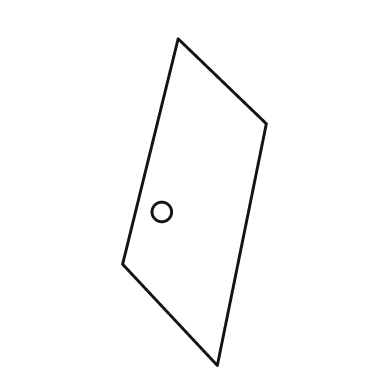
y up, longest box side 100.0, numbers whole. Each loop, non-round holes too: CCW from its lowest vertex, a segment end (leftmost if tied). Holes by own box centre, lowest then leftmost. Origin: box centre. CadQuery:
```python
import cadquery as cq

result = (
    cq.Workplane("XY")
    .moveTo(7.0, -50.0)
    .lineTo(22.0, 24.0)
    .lineTo(-5.0, 50.0)
    .lineTo(-22.0, -19.0)
    .close()
    .moveTo(-10.0, -3.0)
    .circle(3.0)
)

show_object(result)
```